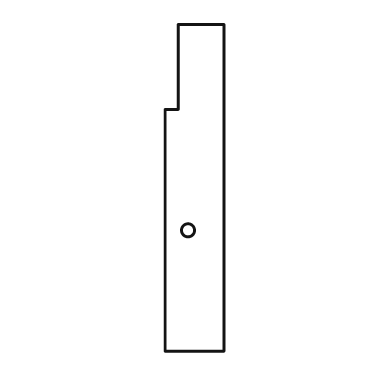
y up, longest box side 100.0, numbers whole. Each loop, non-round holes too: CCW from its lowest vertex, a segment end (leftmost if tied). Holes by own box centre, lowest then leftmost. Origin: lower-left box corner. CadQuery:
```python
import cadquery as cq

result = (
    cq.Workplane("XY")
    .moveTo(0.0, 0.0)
    .lineTo(18.0, 0.0)
    .lineTo(18.0, 100.0)
    .lineTo(4.0, 100.0)
    .lineTo(4.0, 74.0)
    .lineTo(0.0, 74.0)
    .close()
    .moveTo(7.0, 37.0)
    .circle(2.0)
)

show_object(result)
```